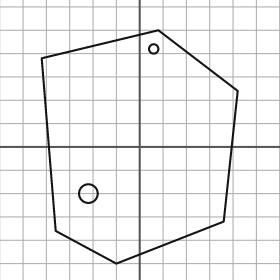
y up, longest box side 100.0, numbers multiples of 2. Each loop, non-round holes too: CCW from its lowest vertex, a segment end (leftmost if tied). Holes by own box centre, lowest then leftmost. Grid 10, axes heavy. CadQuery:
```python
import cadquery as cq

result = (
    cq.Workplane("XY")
    .moveTo(-10.0, -50.0)
    .lineTo(36.0, -32.0)
    .lineTo(42.0, 24.0)
    .lineTo(8.0, 50.0)
    .lineTo(-42.0, 38.0)
    .lineTo(-36.0, -36.0)
    .close()
    .moveTo(-22.0, -20.0)
    .circle(4.0)
    .moveTo(6.0, 42.0)
    .circle(2.0)
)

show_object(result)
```